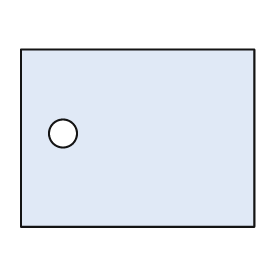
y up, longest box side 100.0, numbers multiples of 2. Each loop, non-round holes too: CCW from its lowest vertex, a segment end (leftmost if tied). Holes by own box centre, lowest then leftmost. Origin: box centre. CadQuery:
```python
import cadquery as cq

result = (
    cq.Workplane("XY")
    .moveTo(-50.0, -38.0)
    .lineTo(50.0, -38.0)
    .lineTo(50.0, 38.0)
    .lineTo(-50.0, 38.0)
    .close()
    .moveTo(-32.0, 2.0)
    .circle(6.0)
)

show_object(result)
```